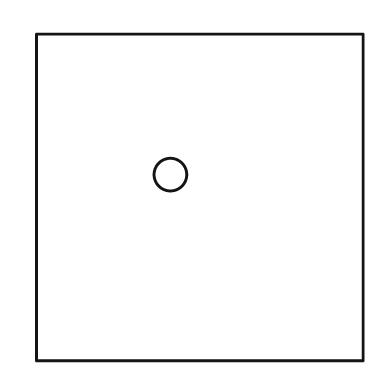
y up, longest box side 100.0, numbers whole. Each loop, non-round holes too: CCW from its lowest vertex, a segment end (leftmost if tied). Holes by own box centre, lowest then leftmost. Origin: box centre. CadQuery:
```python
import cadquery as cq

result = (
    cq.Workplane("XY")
    .moveTo(-50.0, -50.0)
    .lineTo(50.0, -50.0)
    .lineTo(50.0, 50.0)
    .lineTo(-50.0, 50.0)
    .close()
    .moveTo(-9.0, 7.0)
    .circle(5.0)
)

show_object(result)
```